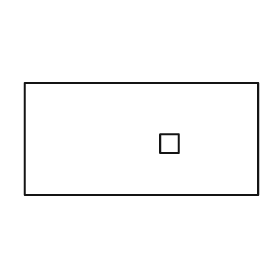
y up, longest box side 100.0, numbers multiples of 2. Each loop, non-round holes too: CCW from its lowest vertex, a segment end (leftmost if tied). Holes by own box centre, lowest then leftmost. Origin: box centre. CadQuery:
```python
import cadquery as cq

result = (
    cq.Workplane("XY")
    .moveTo(-50.0, -24.0)
    .lineTo(50.0, -24.0)
    .lineTo(50.0, 24.0)
    .lineTo(-50.0, 24.0)
    .close()
    .moveTo(8.0, -6.0)
    .lineTo(16.0, -6.0)
    .lineTo(16.0, 2.0)
    .lineTo(8.0, 2.0)
    .close()
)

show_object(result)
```